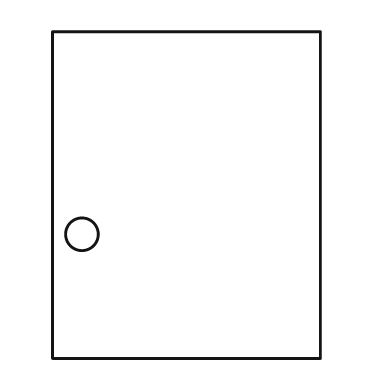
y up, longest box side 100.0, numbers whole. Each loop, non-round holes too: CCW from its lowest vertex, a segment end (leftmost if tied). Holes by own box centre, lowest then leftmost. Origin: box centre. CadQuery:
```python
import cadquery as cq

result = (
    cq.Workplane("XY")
    .moveTo(-41.0, -50.0)
    .lineTo(41.0, -50.0)
    .lineTo(41.0, 50.0)
    .lineTo(-41.0, 50.0)
    .close()
    .moveTo(-32.0, -12.0)
    .circle(5.0)
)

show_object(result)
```